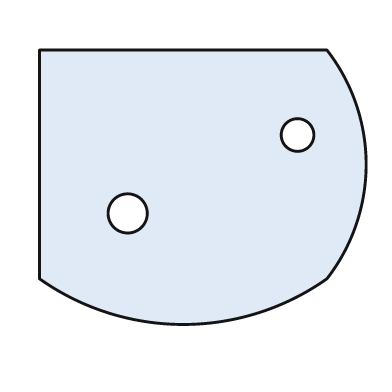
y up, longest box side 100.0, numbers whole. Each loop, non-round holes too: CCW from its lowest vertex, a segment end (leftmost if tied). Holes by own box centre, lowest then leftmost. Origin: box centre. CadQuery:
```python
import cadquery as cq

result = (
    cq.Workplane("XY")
    .moveTo(-50.0, -28.0)
    .threePointArc((-6.0, -42.0), (38.0, -28.0))
    .threePointArc((50.0, 7.0), (38.0, 42.0))
    .lineTo(-50.0, 42.0)
    .close()
    .moveTo(-23.0, -8.0)
    .circle(6.0)
    .moveTo(29.0, 16.0)
    .circle(5.0)
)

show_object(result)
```